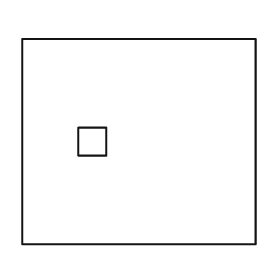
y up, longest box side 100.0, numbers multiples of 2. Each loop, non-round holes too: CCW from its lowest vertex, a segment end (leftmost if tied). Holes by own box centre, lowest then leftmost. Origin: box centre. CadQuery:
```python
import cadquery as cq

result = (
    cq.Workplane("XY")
    .moveTo(-50.0, -44.0)
    .lineTo(50.0, -44.0)
    .lineTo(50.0, 44.0)
    .lineTo(-50.0, 44.0)
    .close()
    .moveTo(-26.0, -6.0)
    .lineTo(-14.0, -6.0)
    .lineTo(-14.0, 6.0)
    .lineTo(-26.0, 6.0)
    .close()
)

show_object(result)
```